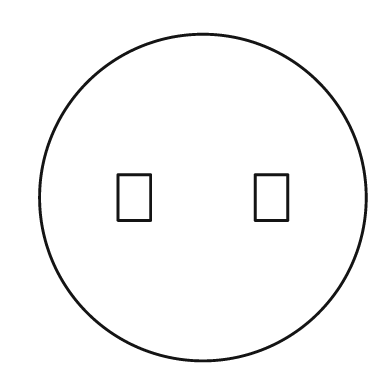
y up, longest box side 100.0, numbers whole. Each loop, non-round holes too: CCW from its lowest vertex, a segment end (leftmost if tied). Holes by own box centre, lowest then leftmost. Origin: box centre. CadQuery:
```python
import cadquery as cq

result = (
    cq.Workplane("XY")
    .moveTo(0.0, 0.0)
    .circle(50.0)
    .moveTo(-26.0, -7.0)
    .lineTo(-16.0, -7.0)
    .lineTo(-16.0, 7.0)
    .lineTo(-26.0, 7.0)
    .close()
    .moveTo(16.0, -7.0)
    .lineTo(26.0, -7.0)
    .lineTo(26.0, 7.0)
    .lineTo(16.0, 7.0)
    .close()
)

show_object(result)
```